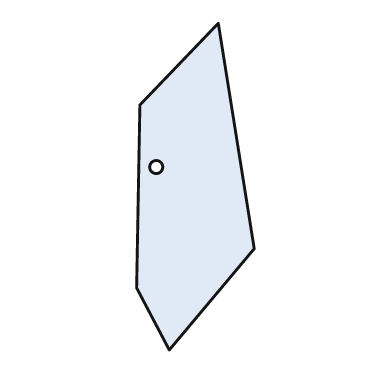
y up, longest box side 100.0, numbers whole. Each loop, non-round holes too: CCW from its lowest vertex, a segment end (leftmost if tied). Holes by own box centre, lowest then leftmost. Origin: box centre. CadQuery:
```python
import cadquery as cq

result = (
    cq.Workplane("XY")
    .moveTo(-8.0, -50.0)
    .lineTo(18.0, -19.0)
    .lineTo(7.0, 50.0)
    .lineTo(-17.0, 25.0)
    .lineTo(-18.0, -31.0)
    .close()
    .moveTo(-12.0, 6.0)
    .circle(2.0)
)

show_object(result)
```